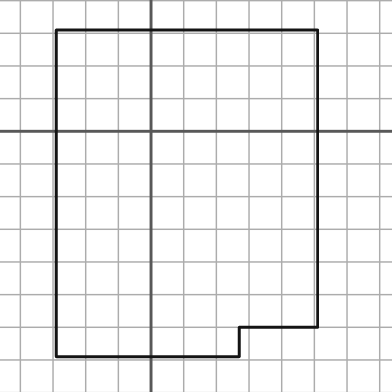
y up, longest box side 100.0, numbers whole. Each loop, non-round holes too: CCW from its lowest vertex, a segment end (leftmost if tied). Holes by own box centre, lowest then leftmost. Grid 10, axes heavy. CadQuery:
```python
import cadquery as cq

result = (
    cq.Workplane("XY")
    .moveTo(-29.0, -69.0)
    .lineTo(27.0, -69.0)
    .lineTo(27.0, -60.0)
    .lineTo(51.0, -60.0)
    .lineTo(51.0, 31.0)
    .lineTo(-29.0, 31.0)
    .close()
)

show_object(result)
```